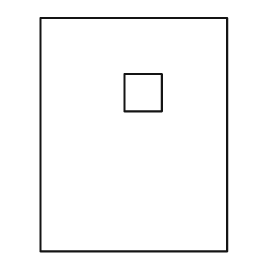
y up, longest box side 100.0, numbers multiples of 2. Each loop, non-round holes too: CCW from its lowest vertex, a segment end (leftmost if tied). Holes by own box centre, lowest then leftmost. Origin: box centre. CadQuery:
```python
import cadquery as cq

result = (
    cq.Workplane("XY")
    .moveTo(-40.0, -50.0)
    .lineTo(40.0, -50.0)
    .lineTo(40.0, 50.0)
    .lineTo(-40.0, 50.0)
    .close()
    .moveTo(-4.0, 10.0)
    .lineTo(12.0, 10.0)
    .lineTo(12.0, 26.0)
    .lineTo(-4.0, 26.0)
    .close()
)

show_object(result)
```